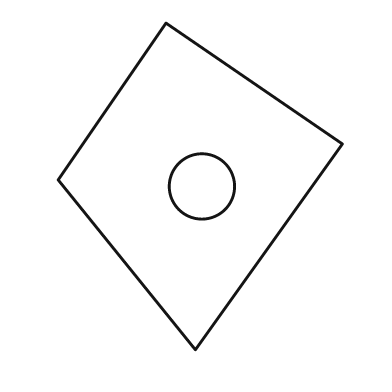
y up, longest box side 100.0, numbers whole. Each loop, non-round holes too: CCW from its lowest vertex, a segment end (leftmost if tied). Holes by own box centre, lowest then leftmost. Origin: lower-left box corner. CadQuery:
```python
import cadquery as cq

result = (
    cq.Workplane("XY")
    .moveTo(42.0, 0.0)
    .lineTo(87.0, 63.0)
    .lineTo(33.0, 100.0)
    .lineTo(0.0, 52.0)
    .close()
    .moveTo(44.0, 50.0)
    .circle(10.0)
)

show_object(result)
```